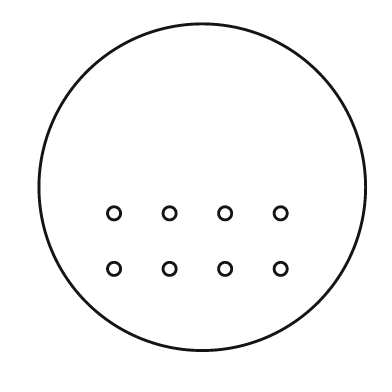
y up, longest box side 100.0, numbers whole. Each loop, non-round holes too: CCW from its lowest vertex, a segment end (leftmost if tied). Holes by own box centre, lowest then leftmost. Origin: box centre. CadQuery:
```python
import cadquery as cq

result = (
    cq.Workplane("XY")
    .moveTo(0.0, 0.0)
    .circle(50.0)
    .moveTo(-27.0, -25.0)
    .circle(2.0)
    .moveTo(-10.0, -25.0)
    .circle(2.0)
    .moveTo(7.0, -25.0)
    .circle(2.0)
    .moveTo(24.0, -25.0)
    .circle(2.0)
    .moveTo(-27.0, -8.0)
    .circle(2.0)
    .moveTo(-10.0, -8.0)
    .circle(2.0)
    .moveTo(7.0, -8.0)
    .circle(2.0)
    .moveTo(24.0, -8.0)
    .circle(2.0)
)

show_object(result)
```